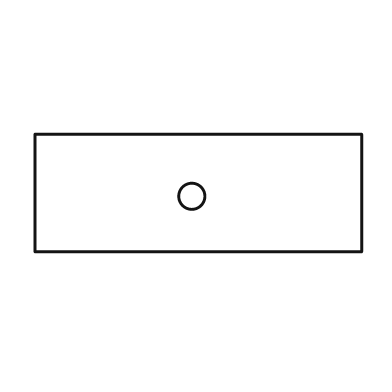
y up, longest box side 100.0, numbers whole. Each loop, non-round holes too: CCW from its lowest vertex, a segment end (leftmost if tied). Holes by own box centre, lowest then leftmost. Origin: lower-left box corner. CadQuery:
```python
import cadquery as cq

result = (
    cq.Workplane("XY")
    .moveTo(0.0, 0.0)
    .lineTo(100.0, 0.0)
    .lineTo(100.0, 36.0)
    .lineTo(0.0, 36.0)
    .close()
    .moveTo(48.0, 17.0)
    .circle(4.0)
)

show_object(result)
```